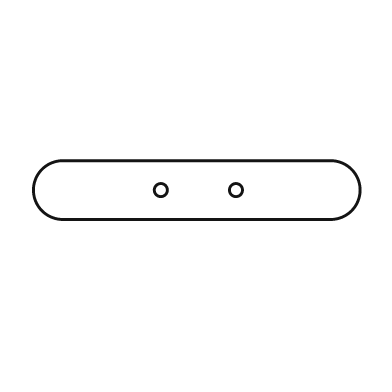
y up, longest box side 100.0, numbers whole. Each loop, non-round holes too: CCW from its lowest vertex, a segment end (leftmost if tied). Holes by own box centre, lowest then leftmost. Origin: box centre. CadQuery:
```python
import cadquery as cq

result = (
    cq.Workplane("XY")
    .moveTo(-41.0, -9.0)
    .lineTo(41.0, -9.0)
    .threePointArc((50.0, 0.0), (41.0, 9.0))
    .lineTo(-41.0, 9.0)
    .threePointArc((-50.0, 0.0), (-41.0, -9.0))
    .close()
    .moveTo(-11.0, 0.0)
    .circle(2.0)
    .moveTo(12.0, 0.0)
    .circle(2.0)
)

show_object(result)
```